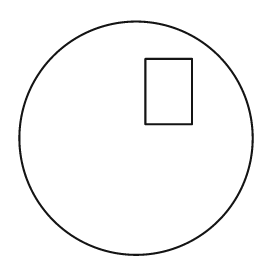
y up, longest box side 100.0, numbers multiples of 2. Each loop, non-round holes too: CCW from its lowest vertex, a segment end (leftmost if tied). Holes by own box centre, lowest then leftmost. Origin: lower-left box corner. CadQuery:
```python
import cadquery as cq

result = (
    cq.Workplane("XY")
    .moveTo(50.0, 50.0)
    .circle(50.0)
    .moveTo(54.0, 56.0)
    .lineTo(74.0, 56.0)
    .lineTo(74.0, 84.0)
    .lineTo(54.0, 84.0)
    .close()
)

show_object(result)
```